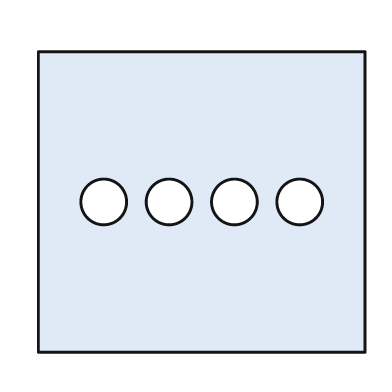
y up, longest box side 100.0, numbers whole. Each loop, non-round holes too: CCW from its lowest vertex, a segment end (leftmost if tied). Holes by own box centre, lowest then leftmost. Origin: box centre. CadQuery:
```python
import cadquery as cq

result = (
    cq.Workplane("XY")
    .moveTo(-50.0, -46.0)
    .lineTo(50.0, -46.0)
    .lineTo(50.0, 46.0)
    .lineTo(-50.0, 46.0)
    .close()
    .moveTo(-30.0, 0.0)
    .circle(7.0)
    .moveTo(-10.0, 0.0)
    .circle(7.0)
    .moveTo(10.0, 0.0)
    .circle(7.0)
    .moveTo(30.0, 0.0)
    .circle(7.0)
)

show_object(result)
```